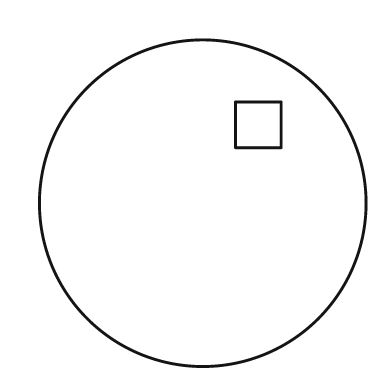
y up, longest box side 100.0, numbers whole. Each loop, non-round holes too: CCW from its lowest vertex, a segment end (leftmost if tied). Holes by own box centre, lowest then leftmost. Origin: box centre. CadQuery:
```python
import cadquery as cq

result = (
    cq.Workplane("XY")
    .moveTo(0.0, 0.0)
    .circle(50.0)
    .moveTo(10.0, 17.0)
    .lineTo(24.0, 17.0)
    .lineTo(24.0, 31.0)
    .lineTo(10.0, 31.0)
    .close()
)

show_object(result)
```